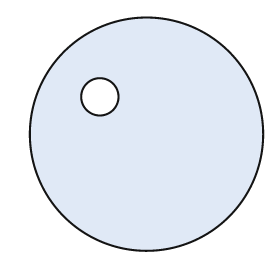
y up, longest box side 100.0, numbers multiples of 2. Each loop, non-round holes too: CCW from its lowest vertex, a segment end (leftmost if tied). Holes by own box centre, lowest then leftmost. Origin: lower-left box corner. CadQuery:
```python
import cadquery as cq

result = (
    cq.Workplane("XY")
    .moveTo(50.0, 50.0)
    .circle(50.0)
    .moveTo(30.0, 66.0)
    .circle(8.0)
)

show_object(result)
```